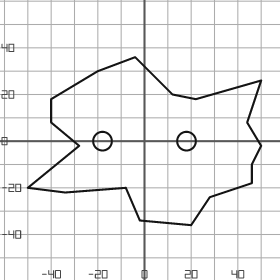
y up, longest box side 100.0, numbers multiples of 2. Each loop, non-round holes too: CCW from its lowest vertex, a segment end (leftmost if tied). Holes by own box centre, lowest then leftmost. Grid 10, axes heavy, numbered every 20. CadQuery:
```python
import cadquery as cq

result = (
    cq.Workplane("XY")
    .moveTo(20.0, -36.0)
    .lineTo(28.0, -24.0)
    .lineTo(46.0, -18.0)
    .lineTo(46.0, -10.0)
    .lineTo(50.0, -2.0)
    .lineTo(44.0, 8.0)
    .lineTo(50.0, 26.0)
    .lineTo(22.0, 18.0)
    .lineTo(12.0, 20.0)
    .lineTo(-4.0, 36.0)
    .lineTo(-20.0, 30.0)
    .lineTo(-40.0, 18.0)
    .lineTo(-40.0, 8.0)
    .lineTo(-28.0, -2.0)
    .lineTo(-50.0, -20.0)
    .lineTo(-34.0, -22.0)
    .lineTo(-8.0, -20.0)
    .lineTo(-2.0, -34.0)
    .close()
    .moveTo(-18.0, 0.0)
    .circle(4.0)
    .moveTo(18.0, 0.0)
    .circle(4.0)
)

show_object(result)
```